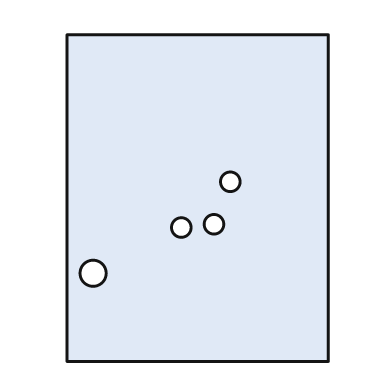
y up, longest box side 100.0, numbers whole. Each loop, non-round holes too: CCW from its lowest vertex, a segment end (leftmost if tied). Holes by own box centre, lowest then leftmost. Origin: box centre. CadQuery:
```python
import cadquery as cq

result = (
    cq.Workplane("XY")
    .moveTo(-40.0, -50.0)
    .lineTo(40.0, -50.0)
    .lineTo(40.0, 50.0)
    .lineTo(-40.0, 50.0)
    .close()
    .moveTo(-32.0, -23.0)
    .circle(4.0)
    .moveTo(-5.0, -9.0)
    .circle(3.0)
    .moveTo(5.0, -8.0)
    .circle(3.0)
    .moveTo(10.0, 5.0)
    .circle(3.0)
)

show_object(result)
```